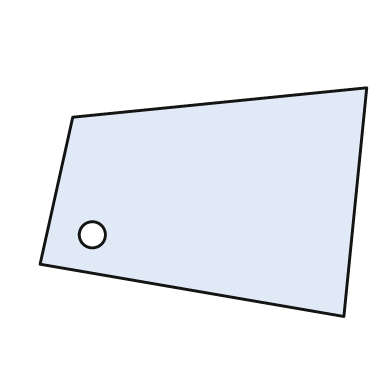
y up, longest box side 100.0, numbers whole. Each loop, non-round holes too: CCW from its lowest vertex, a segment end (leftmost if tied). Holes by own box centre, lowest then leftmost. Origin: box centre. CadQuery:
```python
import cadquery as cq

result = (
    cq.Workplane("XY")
    .moveTo(43.0, -35.0)
    .lineTo(50.0, 35.0)
    .lineTo(-40.0, 26.0)
    .lineTo(-50.0, -19.0)
    .close()
    .moveTo(-34.0, -10.0)
    .circle(4.0)
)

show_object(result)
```